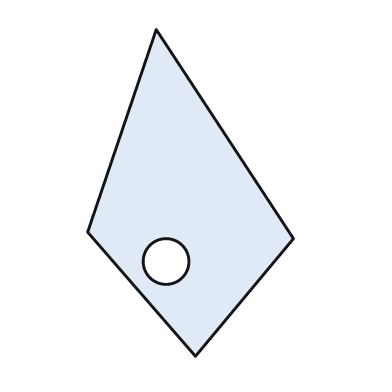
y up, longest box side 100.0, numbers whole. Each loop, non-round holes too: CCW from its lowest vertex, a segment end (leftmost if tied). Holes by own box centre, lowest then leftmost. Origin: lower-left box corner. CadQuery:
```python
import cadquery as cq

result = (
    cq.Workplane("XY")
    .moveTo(33.0, 0.0)
    .lineTo(63.0, 36.0)
    .lineTo(21.0, 100.0)
    .lineTo(0.0, 38.0)
    .close()
    .moveTo(24.0, 29.0)
    .circle(7.0)
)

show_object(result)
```